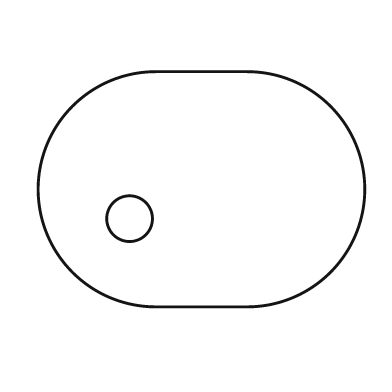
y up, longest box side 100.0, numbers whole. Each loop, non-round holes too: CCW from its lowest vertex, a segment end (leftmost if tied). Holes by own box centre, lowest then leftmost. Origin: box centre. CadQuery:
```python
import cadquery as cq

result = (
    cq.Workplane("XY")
    .moveTo(-14.0, -36.0)
    .lineTo(14.0, -36.0)
    .threePointArc((50.0, 0.0), (14.0, 36.0))
    .lineTo(-14.0, 36.0)
    .threePointArc((-50.0, 0.0), (-14.0, -36.0))
    .close()
    .moveTo(-22.0, -9.0)
    .circle(7.0)
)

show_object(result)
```